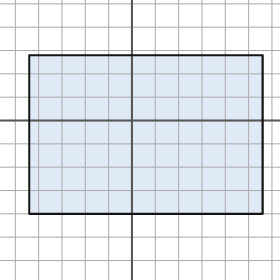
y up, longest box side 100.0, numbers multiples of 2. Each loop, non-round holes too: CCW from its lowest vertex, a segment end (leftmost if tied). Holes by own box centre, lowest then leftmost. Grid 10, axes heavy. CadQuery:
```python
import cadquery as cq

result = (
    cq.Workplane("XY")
    .moveTo(-44.0, -40.0)
    .lineTo(56.0, -40.0)
    .lineTo(56.0, 28.0)
    .lineTo(-44.0, 28.0)
    .close()
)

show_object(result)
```